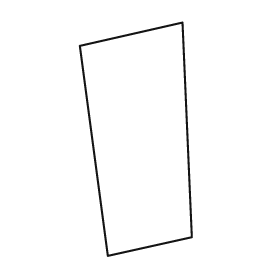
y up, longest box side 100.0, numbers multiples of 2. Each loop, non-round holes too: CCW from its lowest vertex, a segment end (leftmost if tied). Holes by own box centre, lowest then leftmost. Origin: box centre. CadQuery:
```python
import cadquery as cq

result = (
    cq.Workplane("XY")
    .moveTo(-12.0, -50.0)
    .lineTo(24.0, -42.0)
    .lineTo(20.0, 50.0)
    .lineTo(-24.0, 40.0)
    .close()
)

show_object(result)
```